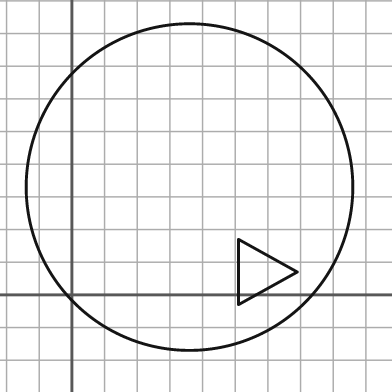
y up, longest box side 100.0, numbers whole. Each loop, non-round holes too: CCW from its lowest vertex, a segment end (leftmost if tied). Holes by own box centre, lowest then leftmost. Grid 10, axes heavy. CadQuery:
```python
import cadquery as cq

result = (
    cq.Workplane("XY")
    .moveTo(36.0, 33.0)
    .circle(50.0)
    .moveTo(51.0, -3.0)
    .lineTo(69.0, 7.0)
    .lineTo(51.0, 17.0)
    .close()
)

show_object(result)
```